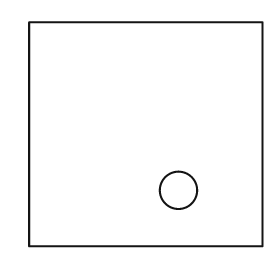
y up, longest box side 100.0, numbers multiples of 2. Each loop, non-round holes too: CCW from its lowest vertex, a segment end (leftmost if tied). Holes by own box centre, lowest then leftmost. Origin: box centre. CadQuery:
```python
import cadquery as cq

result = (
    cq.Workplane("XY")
    .moveTo(-50.0, -48.0)
    .lineTo(50.0, -48.0)
    .lineTo(50.0, 48.0)
    .lineTo(-50.0, 48.0)
    .close()
    .moveTo(14.0, -24.0)
    .circle(8.0)
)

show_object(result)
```